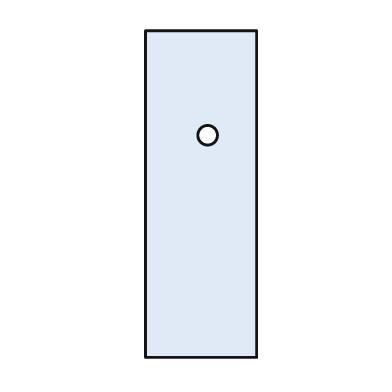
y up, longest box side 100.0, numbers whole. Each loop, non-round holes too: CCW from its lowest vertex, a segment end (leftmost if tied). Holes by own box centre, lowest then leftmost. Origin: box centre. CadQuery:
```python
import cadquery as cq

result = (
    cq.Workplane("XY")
    .moveTo(-17.0, -50.0)
    .lineTo(17.0, -50.0)
    .lineTo(17.0, 50.0)
    .lineTo(-17.0, 50.0)
    .close()
    .moveTo(2.0, 18.0)
    .circle(3.0)
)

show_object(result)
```